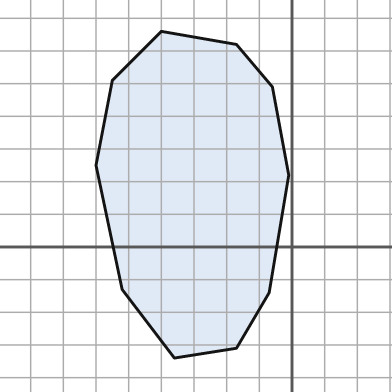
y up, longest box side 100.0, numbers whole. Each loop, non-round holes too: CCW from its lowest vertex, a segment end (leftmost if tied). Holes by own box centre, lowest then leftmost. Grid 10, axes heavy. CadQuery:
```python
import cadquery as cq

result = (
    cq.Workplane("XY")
    .moveTo(-36.0, -34.0)
    .lineTo(-17.0, -31.0)
    .lineTo(-7.0, -14.0)
    .lineTo(-1.0, 22.0)
    .lineTo(-6.0, 49.0)
    .lineTo(-17.0, 62.0)
    .lineTo(-40.0, 66.0)
    .lineTo(-55.0, 51.0)
    .lineTo(-60.0, 25.0)
    .lineTo(-52.0, -13.0)
    .close()
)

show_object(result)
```